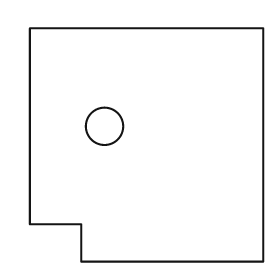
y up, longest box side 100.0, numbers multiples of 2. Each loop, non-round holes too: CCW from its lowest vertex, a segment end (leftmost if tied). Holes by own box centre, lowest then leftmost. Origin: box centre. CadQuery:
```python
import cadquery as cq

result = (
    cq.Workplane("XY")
    .moveTo(-28.0, -50.0)
    .lineTo(50.0, -50.0)
    .lineTo(50.0, 50.0)
    .lineTo(-50.0, 50.0)
    .lineTo(-50.0, -34.0)
    .lineTo(-28.0, -34.0)
    .close()
    .moveTo(-18.0, 8.0)
    .circle(8.0)
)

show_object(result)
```